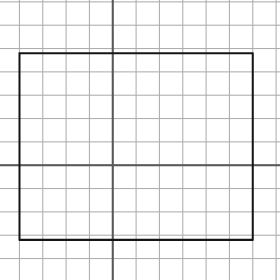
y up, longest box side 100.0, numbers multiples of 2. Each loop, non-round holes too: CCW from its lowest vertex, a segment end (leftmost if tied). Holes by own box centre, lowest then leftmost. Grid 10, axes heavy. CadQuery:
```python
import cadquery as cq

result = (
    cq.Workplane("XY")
    .moveTo(-40.0, -32.0)
    .lineTo(60.0, -32.0)
    .lineTo(60.0, 48.0)
    .lineTo(-40.0, 48.0)
    .close()
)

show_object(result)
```